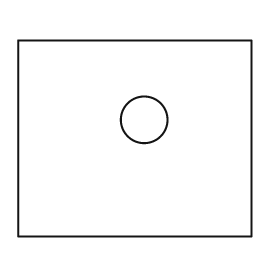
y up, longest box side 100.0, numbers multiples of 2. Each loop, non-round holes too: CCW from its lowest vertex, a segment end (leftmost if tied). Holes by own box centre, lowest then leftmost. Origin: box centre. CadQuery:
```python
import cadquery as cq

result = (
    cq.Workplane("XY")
    .moveTo(-50.0, -42.0)
    .lineTo(50.0, -42.0)
    .lineTo(50.0, 42.0)
    .lineTo(-50.0, 42.0)
    .close()
    .moveTo(4.0, 8.0)
    .circle(10.0)
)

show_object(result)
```